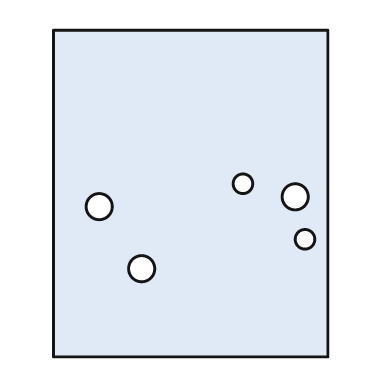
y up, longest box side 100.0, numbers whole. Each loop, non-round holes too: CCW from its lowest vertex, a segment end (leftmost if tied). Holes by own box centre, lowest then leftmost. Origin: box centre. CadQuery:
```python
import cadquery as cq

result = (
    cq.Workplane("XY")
    .moveTo(-42.0, -50.0)
    .lineTo(42.0, -50.0)
    .lineTo(42.0, 50.0)
    .lineTo(-42.0, 50.0)
    .close()
    .moveTo(-15.0, -23.0)
    .circle(4.0)
    .moveTo(35.0, -14.0)
    .circle(3.0)
    .moveTo(-28.0, -4.0)
    .circle(4.0)
    .moveTo(32.0, -1.0)
    .circle(4.0)
    .moveTo(16.0, 3.0)
    .circle(3.0)
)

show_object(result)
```